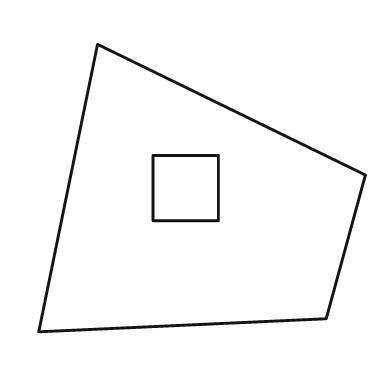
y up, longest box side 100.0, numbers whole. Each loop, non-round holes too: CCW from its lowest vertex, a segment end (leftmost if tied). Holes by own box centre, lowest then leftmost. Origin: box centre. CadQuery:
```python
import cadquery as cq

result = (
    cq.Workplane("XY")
    .moveTo(-50.0, -44.0)
    .lineTo(38.0, -40.0)
    .lineTo(50.0, 4.0)
    .lineTo(-32.0, 44.0)
    .close()
    .moveTo(-15.0, -10.0)
    .lineTo(5.0, -10.0)
    .lineTo(5.0, 10.0)
    .lineTo(-15.0, 10.0)
    .close()
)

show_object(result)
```